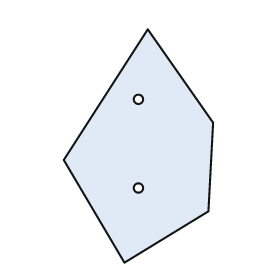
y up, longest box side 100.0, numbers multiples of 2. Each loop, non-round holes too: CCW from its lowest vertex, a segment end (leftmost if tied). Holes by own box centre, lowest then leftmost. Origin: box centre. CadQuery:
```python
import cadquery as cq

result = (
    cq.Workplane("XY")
    .moveTo(-6.0, -50.0)
    .lineTo(30.0, -28.0)
    .lineTo(32.0, 10.0)
    .lineTo(4.0, 50.0)
    .lineTo(-32.0, -6.0)
    .close()
    .moveTo(0.0, -18.0)
    .circle(2.0)
    .moveTo(0.0, 20.0)
    .circle(2.0)
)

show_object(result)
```